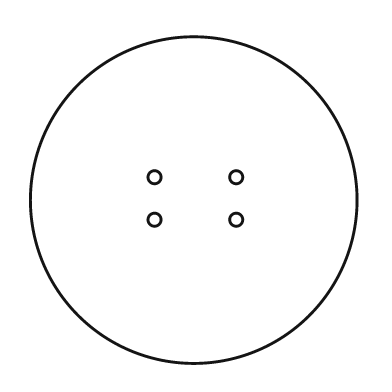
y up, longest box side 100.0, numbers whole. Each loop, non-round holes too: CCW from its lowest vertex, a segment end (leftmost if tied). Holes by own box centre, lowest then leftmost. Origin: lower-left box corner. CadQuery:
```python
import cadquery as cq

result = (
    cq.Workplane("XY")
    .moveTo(50.0, 50.0)
    .circle(50.0)
    .moveTo(38.0, 44.0)
    .circle(2.0)
    .moveTo(63.0, 44.0)
    .circle(2.0)
    .moveTo(38.0, 57.0)
    .circle(2.0)
    .moveTo(63.0, 57.0)
    .circle(2.0)
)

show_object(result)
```